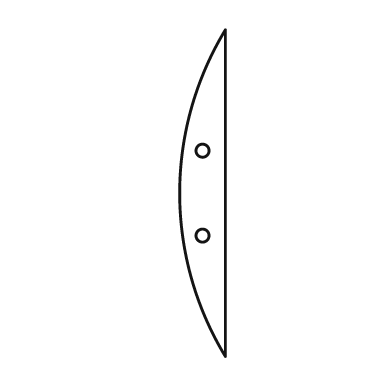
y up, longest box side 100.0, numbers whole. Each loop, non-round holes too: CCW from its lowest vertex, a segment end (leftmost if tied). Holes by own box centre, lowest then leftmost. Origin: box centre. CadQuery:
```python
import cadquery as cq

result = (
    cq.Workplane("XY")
    .moveTo(7.0, -50.0)
    .lineTo(7.0, 50.0)
    .threePointArc((-7.0, 0.0), (7.0, -50.0))
    .close()
    .moveTo(0.0, -13.0)
    .circle(2.0)
    .moveTo(0.0, 13.0)
    .circle(2.0)
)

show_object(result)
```